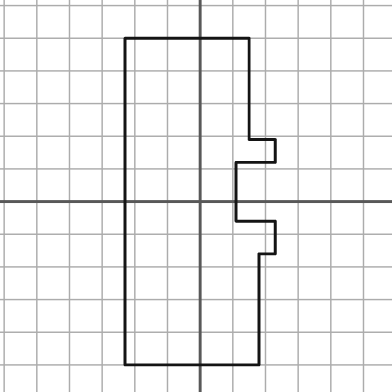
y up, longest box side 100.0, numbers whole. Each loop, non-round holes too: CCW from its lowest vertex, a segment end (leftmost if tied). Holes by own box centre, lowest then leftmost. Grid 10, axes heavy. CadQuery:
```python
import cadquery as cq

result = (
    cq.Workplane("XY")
    .moveTo(-23.0, -50.0)
    .lineTo(18.0, -50.0)
    .lineTo(18.0, -16.0)
    .lineTo(23.0, -16.0)
    .lineTo(23.0, -6.0)
    .lineTo(11.0, -6.0)
    .lineTo(11.0, 12.0)
    .lineTo(23.0, 12.0)
    .lineTo(23.0, 19.0)
    .lineTo(15.0, 19.0)
    .lineTo(15.0, 50.0)
    .lineTo(-23.0, 50.0)
    .close()
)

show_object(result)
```